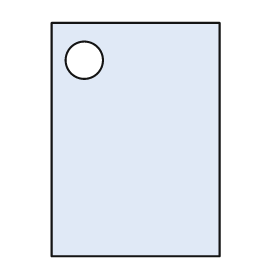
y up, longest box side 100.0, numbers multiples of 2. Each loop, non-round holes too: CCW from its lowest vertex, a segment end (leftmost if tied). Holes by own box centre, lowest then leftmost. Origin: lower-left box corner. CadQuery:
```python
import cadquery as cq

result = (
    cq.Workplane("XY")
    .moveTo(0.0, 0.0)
    .lineTo(72.0, 0.0)
    .lineTo(72.0, 100.0)
    .lineTo(0.0, 100.0)
    .close()
    .moveTo(14.0, 84.0)
    .circle(8.0)
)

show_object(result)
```